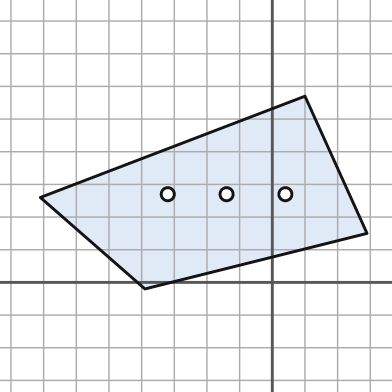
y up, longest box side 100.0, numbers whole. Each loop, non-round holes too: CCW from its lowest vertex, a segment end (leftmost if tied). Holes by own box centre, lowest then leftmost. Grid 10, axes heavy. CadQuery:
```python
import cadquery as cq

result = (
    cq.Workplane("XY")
    .moveTo(-39.0, -2.0)
    .lineTo(29.0, 15.0)
    .lineTo(10.0, 57.0)
    .lineTo(-71.0, 26.0)
    .close()
    .moveTo(-32.0, 27.0)
    .circle(2.0)
    .moveTo(-14.0, 27.0)
    .circle(2.0)
    .moveTo(4.0, 27.0)
    .circle(2.0)
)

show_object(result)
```